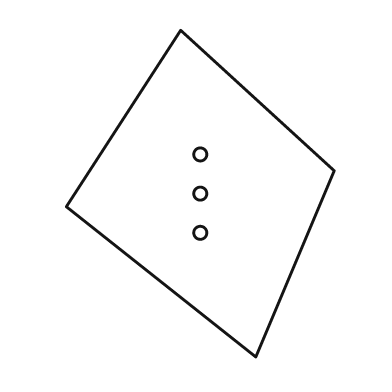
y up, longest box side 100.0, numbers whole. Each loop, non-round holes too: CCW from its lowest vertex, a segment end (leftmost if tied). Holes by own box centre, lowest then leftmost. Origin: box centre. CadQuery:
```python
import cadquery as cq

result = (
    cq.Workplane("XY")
    .moveTo(17.0, -50.0)
    .lineTo(41.0, 7.0)
    .lineTo(-6.0, 50.0)
    .lineTo(-41.0, -4.0)
    .close()
    .moveTo(0.0, -12.0)
    .circle(2.0)
    .moveTo(0.0, 0.0)
    .circle(2.0)
    .moveTo(0.0, 12.0)
    .circle(2.0)
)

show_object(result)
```